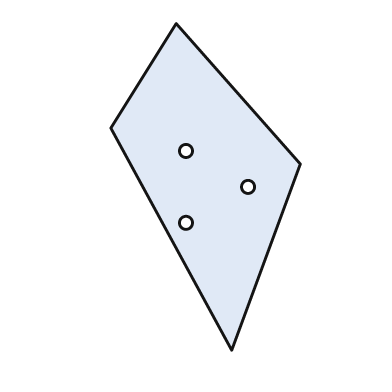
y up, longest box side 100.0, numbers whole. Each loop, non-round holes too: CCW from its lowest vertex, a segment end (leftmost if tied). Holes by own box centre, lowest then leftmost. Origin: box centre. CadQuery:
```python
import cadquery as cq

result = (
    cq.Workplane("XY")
    .moveTo(8.0, -50.0)
    .lineTo(29.0, 7.0)
    .lineTo(-9.0, 50.0)
    .lineTo(-29.0, 18.0)
    .close()
    .moveTo(-6.0, -11.0)
    .circle(2.0)
    .moveTo(13.0, 0.0)
    .circle(2.0)
    .moveTo(-6.0, 11.0)
    .circle(2.0)
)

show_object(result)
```